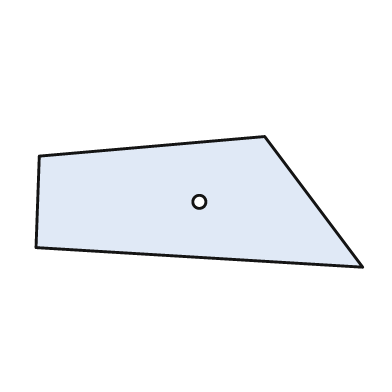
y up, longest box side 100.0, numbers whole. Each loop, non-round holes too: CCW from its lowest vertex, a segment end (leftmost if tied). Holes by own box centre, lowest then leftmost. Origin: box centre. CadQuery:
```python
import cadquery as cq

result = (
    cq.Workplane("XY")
    .moveTo(50.0, -20.0)
    .lineTo(20.0, 20.0)
    .lineTo(-49.0, 14.0)
    .lineTo(-50.0, -14.0)
    .close()
    .moveTo(0.0, 0.0)
    .circle(2.0)
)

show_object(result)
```